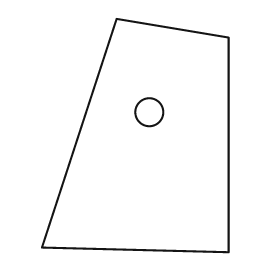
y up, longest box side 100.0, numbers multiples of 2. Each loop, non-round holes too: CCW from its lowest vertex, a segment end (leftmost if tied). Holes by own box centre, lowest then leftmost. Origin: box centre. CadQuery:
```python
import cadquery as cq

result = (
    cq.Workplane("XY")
    .moveTo(40.0, -50.0)
    .lineTo(40.0, 42.0)
    .lineTo(-8.0, 50.0)
    .lineTo(-40.0, -48.0)
    .close()
    .moveTo(6.0, 10.0)
    .circle(6.0)
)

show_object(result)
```